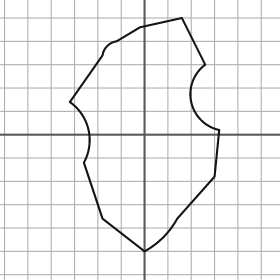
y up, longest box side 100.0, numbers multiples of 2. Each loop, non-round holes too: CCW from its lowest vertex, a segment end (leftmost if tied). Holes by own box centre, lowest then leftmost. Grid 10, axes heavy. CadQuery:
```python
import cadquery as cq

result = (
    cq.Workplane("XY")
    .moveTo(0.0, -50.0)
    .threePointArc((8.0, -44.0), (14.0, -36.0))
    .lineTo(30.0, -18.0)
    .lineTo(32.0, 2.0)
    .threePointArc((20.0, 14.0), (26.0, 30.0))
    .lineTo(16.0, 50.0)
    .lineTo(-2.0, 46.0)
    .lineTo(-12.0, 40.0)
    .threePointArc((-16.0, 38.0), (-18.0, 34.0))
    .lineTo(-32.0, 14.0)
    .threePointArc((-24.0, 2.0), (-26.0, -12.0))
    .lineTo(-18.0, -36.0)
    .close()
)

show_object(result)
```